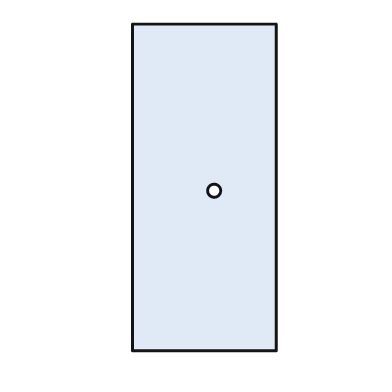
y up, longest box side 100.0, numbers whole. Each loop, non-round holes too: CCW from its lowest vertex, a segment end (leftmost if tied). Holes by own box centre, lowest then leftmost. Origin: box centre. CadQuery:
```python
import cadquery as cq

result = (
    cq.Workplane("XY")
    .moveTo(-22.0, -50.0)
    .lineTo(22.0, -50.0)
    .lineTo(22.0, 50.0)
    .lineTo(-22.0, 50.0)
    .close()
    .moveTo(3.0, -1.0)
    .circle(2.0)
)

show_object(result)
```